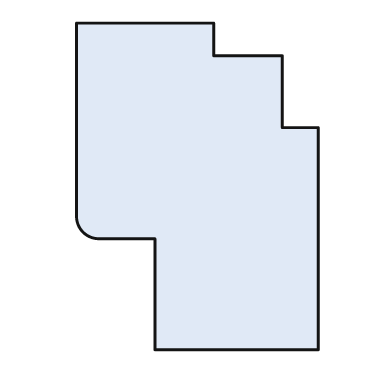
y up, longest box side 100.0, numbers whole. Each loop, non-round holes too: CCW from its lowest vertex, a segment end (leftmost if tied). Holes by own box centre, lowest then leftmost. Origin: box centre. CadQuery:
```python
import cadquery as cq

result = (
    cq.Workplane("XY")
    .moveTo(-13.0, -50.0)
    .lineTo(37.0, -50.0)
    .lineTo(37.0, 18.0)
    .lineTo(26.0, 18.0)
    .lineTo(26.0, 40.0)
    .lineTo(5.0, 40.0)
    .lineTo(5.0, 50.0)
    .lineTo(-37.0, 50.0)
    .lineTo(-37.0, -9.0)
    .threePointArc((-35.0, -14.0), (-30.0, -16.0))
    .lineTo(-13.0, -16.0)
    .close()
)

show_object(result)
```